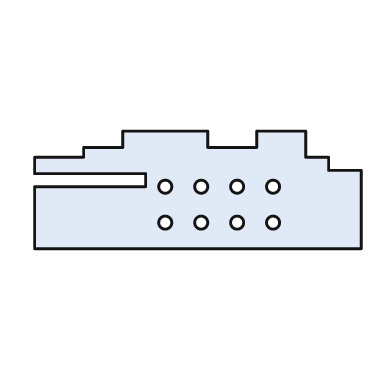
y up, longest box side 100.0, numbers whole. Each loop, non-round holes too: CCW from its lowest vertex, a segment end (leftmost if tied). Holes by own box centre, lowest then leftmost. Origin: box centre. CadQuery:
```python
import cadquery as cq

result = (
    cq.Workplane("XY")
    .moveTo(-50.0, -18.0)
    .lineTo(50.0, -18.0)
    .lineTo(50.0, 6.0)
    .lineTo(40.0, 6.0)
    .lineTo(40.0, 10.0)
    .lineTo(33.0, 10.0)
    .lineTo(33.0, 18.0)
    .lineTo(18.0, 18.0)
    .lineTo(18.0, 13.0)
    .lineTo(3.0, 13.0)
    .lineTo(3.0, 18.0)
    .lineTo(-23.0, 18.0)
    .lineTo(-23.0, 13.0)
    .lineTo(-35.0, 13.0)
    .lineTo(-35.0, 10.0)
    .lineTo(-50.0, 10.0)
    .lineTo(-50.0, 5.0)
    .lineTo(-16.0, 5.0)
    .lineTo(-16.0, 1.0)
    .lineTo(-50.0, 1.0)
    .close()
    .moveTo(-10.0, -10.0)
    .circle(2.0)
    .moveTo(1.0, -10.0)
    .circle(2.0)
    .moveTo(12.0, -10.0)
    .circle(2.0)
    .moveTo(23.0, -10.0)
    .circle(2.0)
    .moveTo(-10.0, 1.0)
    .circle(2.0)
    .moveTo(1.0, 1.0)
    .circle(2.0)
    .moveTo(12.0, 1.0)
    .circle(2.0)
    .moveTo(23.0, 1.0)
    .circle(2.0)
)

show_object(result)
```